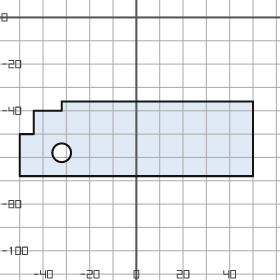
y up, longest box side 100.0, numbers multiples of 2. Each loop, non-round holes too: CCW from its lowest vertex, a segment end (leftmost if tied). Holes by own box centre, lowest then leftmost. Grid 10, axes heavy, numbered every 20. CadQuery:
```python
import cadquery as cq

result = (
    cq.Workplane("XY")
    .moveTo(-50.0, -68.0)
    .lineTo(50.0, -68.0)
    .lineTo(50.0, -36.0)
    .lineTo(-32.0, -36.0)
    .lineTo(-32.0, -40.0)
    .lineTo(-44.0, -40.0)
    .lineTo(-44.0, -50.0)
    .lineTo(-50.0, -50.0)
    .close()
    .moveTo(-32.0, -58.0)
    .circle(4.0)
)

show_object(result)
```